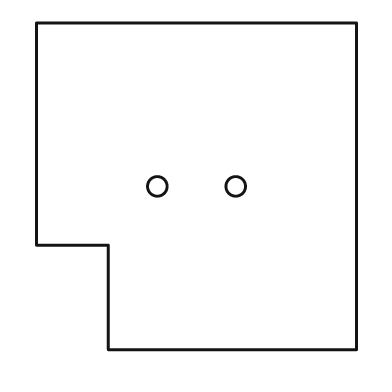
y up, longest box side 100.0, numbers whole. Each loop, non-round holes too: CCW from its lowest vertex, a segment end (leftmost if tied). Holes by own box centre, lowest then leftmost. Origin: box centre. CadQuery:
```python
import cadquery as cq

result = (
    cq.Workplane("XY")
    .moveTo(-27.0, -50.0)
    .lineTo(49.0, -50.0)
    .lineTo(49.0, 50.0)
    .lineTo(-49.0, 50.0)
    .lineTo(-49.0, -18.0)
    .lineTo(-27.0, -18.0)
    .close()
    .moveTo(-12.0, 0.0)
    .circle(3.0)
    .moveTo(12.0, 0.0)
    .circle(3.0)
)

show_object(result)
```